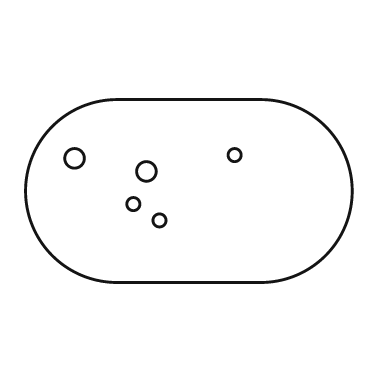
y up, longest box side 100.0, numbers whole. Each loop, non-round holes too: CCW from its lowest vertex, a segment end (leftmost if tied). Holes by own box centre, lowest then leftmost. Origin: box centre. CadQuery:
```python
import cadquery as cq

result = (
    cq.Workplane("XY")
    .moveTo(-22.0, -28.0)
    .lineTo(22.0, -28.0)
    .threePointArc((50.0, 0.0), (22.0, 28.0))
    .lineTo(-22.0, 28.0)
    .threePointArc((-50.0, 0.0), (-22.0, -28.0))
    .close()
    .moveTo(-9.0, -9.0)
    .circle(2.0)
    .moveTo(-17.0, -4.0)
    .circle(2.0)
    .moveTo(-13.0, 6.0)
    .circle(3.0)
    .moveTo(-35.0, 10.0)
    .circle(3.0)
    .moveTo(14.0, 11.0)
    .circle(2.0)
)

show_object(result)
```